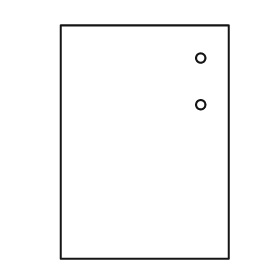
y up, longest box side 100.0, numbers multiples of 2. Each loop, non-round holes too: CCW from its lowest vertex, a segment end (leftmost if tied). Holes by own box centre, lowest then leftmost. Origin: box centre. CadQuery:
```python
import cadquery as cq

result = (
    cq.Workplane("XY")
    .moveTo(-36.0, -50.0)
    .lineTo(36.0, -50.0)
    .lineTo(36.0, 50.0)
    .lineTo(-36.0, 50.0)
    .close()
    .moveTo(24.0, 16.0)
    .circle(2.0)
    .moveTo(24.0, 36.0)
    .circle(2.0)
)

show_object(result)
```